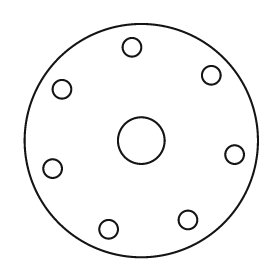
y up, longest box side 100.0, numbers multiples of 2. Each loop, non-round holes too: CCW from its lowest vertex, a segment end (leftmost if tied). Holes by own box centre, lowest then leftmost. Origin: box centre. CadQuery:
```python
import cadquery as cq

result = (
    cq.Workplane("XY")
    .moveTo(0.0, 0.0)
    .circle(50.0)
    .moveTo(-14.0, -38.0)
    .circle(4.0)
    .moveTo(20.0, -34.0)
    .circle(4.0)
    .moveTo(-38.0, -12.0)
    .circle(4.0)
    .moveTo(40.0, -6.0)
    .circle(4.0)
    .moveTo(0.0, 0.0)
    .circle(10.0)
    .moveTo(-34.0, 22.0)
    .circle(4.0)
    .moveTo(30.0, 28.0)
    .circle(4.0)
    .moveTo(-4.0, 40.0)
    .circle(4.0)
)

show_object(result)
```